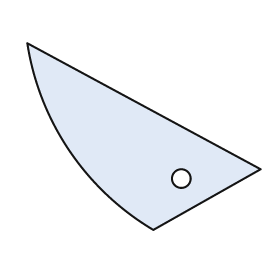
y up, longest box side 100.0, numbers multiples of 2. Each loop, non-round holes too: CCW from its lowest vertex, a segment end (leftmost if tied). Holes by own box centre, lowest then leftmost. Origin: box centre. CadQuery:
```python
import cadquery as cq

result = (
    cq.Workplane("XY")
    .moveTo(4.0, -40.0)
    .lineTo(50.0, -14.0)
    .lineTo(-50.0, 40.0)
    .threePointArc((-32.0, -6.0), (4.0, -40.0))
    .close()
    .moveTo(16.0, -18.0)
    .circle(4.0)
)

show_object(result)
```